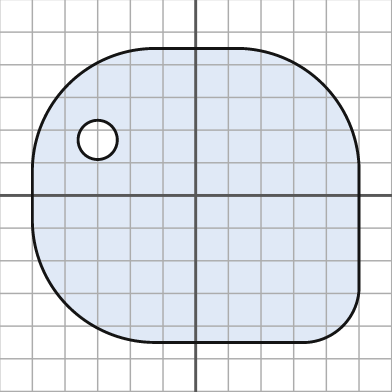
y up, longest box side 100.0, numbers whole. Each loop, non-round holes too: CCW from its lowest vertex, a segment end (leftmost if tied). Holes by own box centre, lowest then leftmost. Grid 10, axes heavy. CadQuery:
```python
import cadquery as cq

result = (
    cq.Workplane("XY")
    .moveTo(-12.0, -45.0)
    .lineTo(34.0, -45.0)
    .threePointArc((45.0, -40.0), (50.0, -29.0))
    .lineTo(50.0, 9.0)
    .threePointArc((39.0, 34.0), (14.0, 45.0))
    .lineTo(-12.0, 45.0)
    .threePointArc((-39.0, 34.0), (-50.0, 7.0))
    .lineTo(-50.0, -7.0)
    .threePointArc((-39.0, -34.0), (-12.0, -45.0))
    .close()
    .moveTo(-30.0, 17.0)
    .circle(6.0)
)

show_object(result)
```